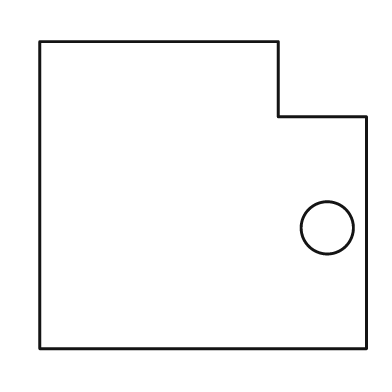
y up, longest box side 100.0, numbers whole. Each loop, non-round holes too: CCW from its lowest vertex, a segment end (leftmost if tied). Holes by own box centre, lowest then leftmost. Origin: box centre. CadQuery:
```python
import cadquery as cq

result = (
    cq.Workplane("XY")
    .moveTo(-50.0, -47.0)
    .lineTo(50.0, -47.0)
    .lineTo(50.0, 24.0)
    .lineTo(23.0, 24.0)
    .lineTo(23.0, 47.0)
    .lineTo(-50.0, 47.0)
    .close()
    .moveTo(38.0, -10.0)
    .circle(8.0)
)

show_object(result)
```